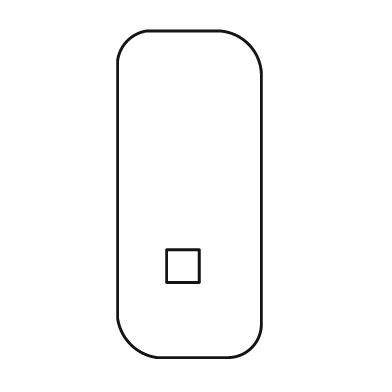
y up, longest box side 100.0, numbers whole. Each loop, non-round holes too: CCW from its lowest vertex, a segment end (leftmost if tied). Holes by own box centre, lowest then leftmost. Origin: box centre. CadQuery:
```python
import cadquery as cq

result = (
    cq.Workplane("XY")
    .moveTo(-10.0, -50.0)
    .lineTo(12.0, -50.0)
    .threePointArc((19.0, -47.0), (22.0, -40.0))
    .lineTo(22.0, 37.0)
    .threePointArc((18.0, 46.0), (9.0, 50.0))
    .lineTo(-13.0, 50.0)
    .threePointArc((-19.0, 47.0), (-22.0, 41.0))
    .lineTo(-22.0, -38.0)
    .threePointArc((-18.0, -46.0), (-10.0, -50.0))
    .close()
    .moveTo(-7.0, -27.0)
    .lineTo(3.0, -27.0)
    .lineTo(3.0, -17.0)
    .lineTo(-7.0, -17.0)
    .close()
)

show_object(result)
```